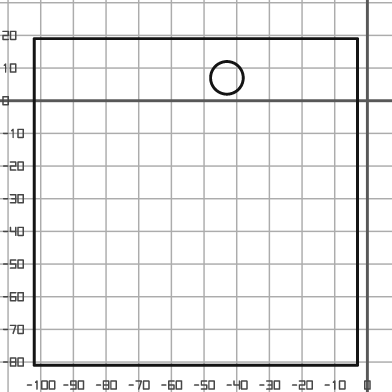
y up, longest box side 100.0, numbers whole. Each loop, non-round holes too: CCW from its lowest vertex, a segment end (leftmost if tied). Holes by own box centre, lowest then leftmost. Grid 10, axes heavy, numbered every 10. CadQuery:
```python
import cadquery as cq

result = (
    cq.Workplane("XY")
    .moveTo(-102.0, -81.0)
    .lineTo(-3.0, -81.0)
    .lineTo(-3.0, 19.0)
    .lineTo(-102.0, 19.0)
    .close()
    .moveTo(-43.0, 7.0)
    .circle(5.0)
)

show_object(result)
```